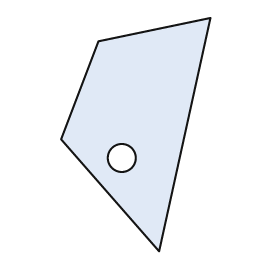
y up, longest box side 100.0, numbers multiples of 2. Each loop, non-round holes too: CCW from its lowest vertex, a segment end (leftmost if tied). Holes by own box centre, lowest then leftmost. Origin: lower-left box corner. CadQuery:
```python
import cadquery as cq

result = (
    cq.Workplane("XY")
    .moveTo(42.0, 0.0)
    .lineTo(64.0, 100.0)
    .lineTo(16.0, 90.0)
    .lineTo(0.0, 48.0)
    .close()
    .moveTo(26.0, 40.0)
    .circle(6.0)
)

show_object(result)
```